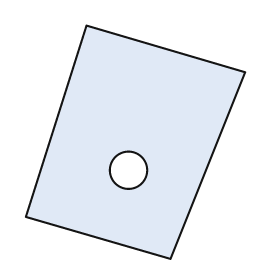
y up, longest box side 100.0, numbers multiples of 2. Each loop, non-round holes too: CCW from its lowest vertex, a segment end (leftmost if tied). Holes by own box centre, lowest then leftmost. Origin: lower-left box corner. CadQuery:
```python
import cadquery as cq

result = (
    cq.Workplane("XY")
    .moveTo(62.0, 0.0)
    .lineTo(94.0, 80.0)
    .lineTo(26.0, 100.0)
    .lineTo(0.0, 18.0)
    .close()
    .moveTo(44.0, 38.0)
    .circle(8.0)
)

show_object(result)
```